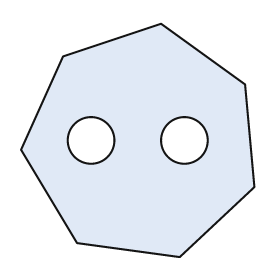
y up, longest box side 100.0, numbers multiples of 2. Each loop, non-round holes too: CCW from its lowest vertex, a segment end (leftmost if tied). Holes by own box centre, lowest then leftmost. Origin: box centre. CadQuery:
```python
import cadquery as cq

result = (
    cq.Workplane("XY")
    .moveTo(18.0, -50.0)
    .lineTo(50.0, -20.0)
    .lineTo(46.0, 24.0)
    .lineTo(10.0, 50.0)
    .lineTo(-32.0, 36.0)
    .lineTo(-50.0, -4.0)
    .lineTo(-26.0, -44.0)
    .close()
    .moveTo(-20.0, 0.0)
    .circle(10.0)
    .moveTo(20.0, 0.0)
    .circle(10.0)
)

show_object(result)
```